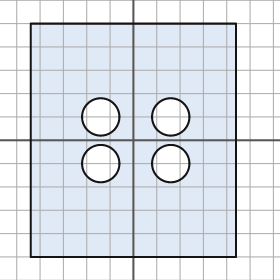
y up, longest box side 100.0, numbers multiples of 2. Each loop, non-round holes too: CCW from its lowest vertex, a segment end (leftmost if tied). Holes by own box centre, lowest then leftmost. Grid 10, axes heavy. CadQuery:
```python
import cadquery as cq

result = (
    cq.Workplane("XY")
    .moveTo(-44.0, -50.0)
    .lineTo(44.0, -50.0)
    .lineTo(44.0, 50.0)
    .lineTo(-44.0, 50.0)
    .close()
    .moveTo(-14.0, -10.0)
    .circle(8.0)
    .moveTo(16.0, -10.0)
    .circle(8.0)
    .moveTo(-14.0, 10.0)
    .circle(8.0)
    .moveTo(16.0, 10.0)
    .circle(8.0)
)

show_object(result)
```